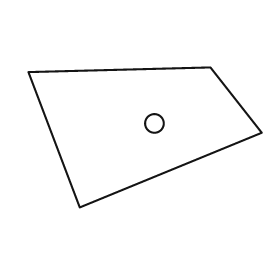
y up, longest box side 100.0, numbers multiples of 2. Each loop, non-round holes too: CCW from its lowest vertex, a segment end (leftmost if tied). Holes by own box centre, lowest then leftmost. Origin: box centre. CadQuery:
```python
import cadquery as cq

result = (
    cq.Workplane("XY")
    .moveTo(-28.0, -30.0)
    .lineTo(50.0, 2.0)
    .lineTo(28.0, 30.0)
    .lineTo(-50.0, 28.0)
    .close()
    .moveTo(4.0, 6.0)
    .circle(4.0)
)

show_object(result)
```